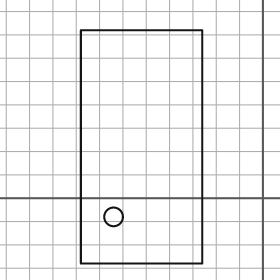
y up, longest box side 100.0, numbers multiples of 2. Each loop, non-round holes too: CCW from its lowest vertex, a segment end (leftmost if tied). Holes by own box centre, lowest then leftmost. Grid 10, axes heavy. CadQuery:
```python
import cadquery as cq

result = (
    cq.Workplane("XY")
    .moveTo(-78.0, -28.0)
    .lineTo(-26.0, -28.0)
    .lineTo(-26.0, 72.0)
    .lineTo(-78.0, 72.0)
    .close()
    .moveTo(-64.0, -8.0)
    .circle(4.0)
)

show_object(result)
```